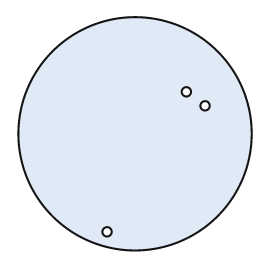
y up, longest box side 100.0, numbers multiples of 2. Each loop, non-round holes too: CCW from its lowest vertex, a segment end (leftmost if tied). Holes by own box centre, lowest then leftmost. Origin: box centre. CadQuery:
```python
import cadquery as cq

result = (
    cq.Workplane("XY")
    .moveTo(0.0, 0.0)
    .circle(50.0)
    .moveTo(-12.0, -42.0)
    .circle(2.0)
    .moveTo(30.0, 12.0)
    .circle(2.0)
    .moveTo(22.0, 18.0)
    .circle(2.0)
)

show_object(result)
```